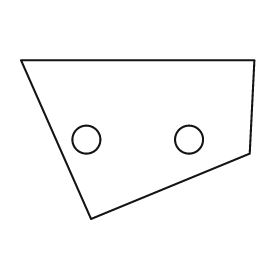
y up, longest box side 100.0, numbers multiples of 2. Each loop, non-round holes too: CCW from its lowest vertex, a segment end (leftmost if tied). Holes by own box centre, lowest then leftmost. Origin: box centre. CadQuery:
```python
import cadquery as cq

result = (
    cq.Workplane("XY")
    .moveTo(-20.0, -34.0)
    .lineTo(48.0, -6.0)
    .lineTo(50.0, 34.0)
    .lineTo(-50.0, 34.0)
    .close()
    .moveTo(-22.0, 0.0)
    .circle(6.0)
    .moveTo(22.0, 0.0)
    .circle(6.0)
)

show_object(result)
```